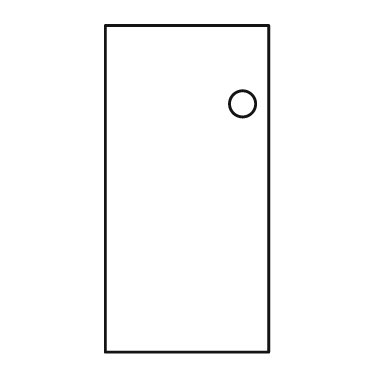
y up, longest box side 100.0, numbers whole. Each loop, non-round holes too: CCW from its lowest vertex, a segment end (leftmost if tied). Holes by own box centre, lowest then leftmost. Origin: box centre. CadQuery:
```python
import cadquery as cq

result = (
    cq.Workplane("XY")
    .moveTo(-25.0, -50.0)
    .lineTo(25.0, -50.0)
    .lineTo(25.0, 50.0)
    .lineTo(-25.0, 50.0)
    .close()
    .moveTo(17.0, 26.0)
    .circle(4.0)
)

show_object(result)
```